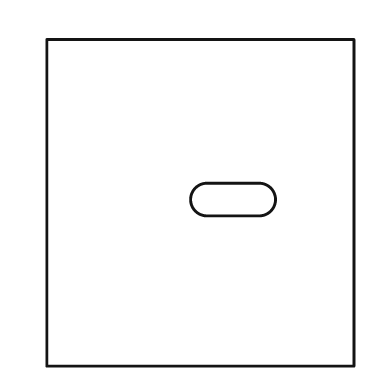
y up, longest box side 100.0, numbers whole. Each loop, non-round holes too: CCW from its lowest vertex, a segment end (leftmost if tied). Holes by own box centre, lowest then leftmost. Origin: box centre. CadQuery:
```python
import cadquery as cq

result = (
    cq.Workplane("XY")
    .moveTo(-47.0, -50.0)
    .lineTo(47.0, -50.0)
    .lineTo(47.0, 50.0)
    .lineTo(-47.0, 50.0)
    .close()
    .moveTo(2.0, -4.0)
    .lineTo(18.0, -4.0)
    .threePointArc((23.0, 1.0), (18.0, 6.0))
    .lineTo(2.0, 6.0)
    .threePointArc((-3.0, 1.0), (2.0, -4.0))
    .close()
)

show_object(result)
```